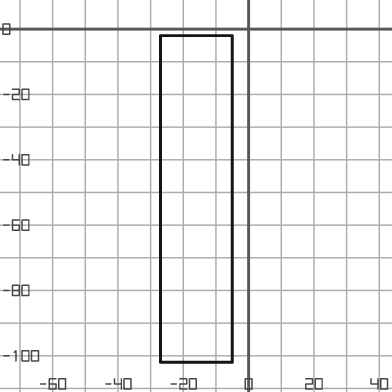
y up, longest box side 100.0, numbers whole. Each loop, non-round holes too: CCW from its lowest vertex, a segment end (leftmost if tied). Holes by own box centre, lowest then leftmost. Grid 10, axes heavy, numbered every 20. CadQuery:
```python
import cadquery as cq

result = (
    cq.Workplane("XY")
    .moveTo(-27.0, -102.0)
    .lineTo(-5.0, -102.0)
    .lineTo(-5.0, -2.0)
    .lineTo(-27.0, -2.0)
    .close()
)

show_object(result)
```